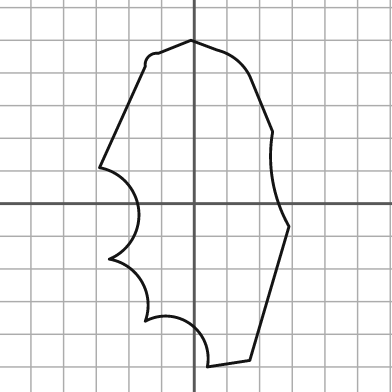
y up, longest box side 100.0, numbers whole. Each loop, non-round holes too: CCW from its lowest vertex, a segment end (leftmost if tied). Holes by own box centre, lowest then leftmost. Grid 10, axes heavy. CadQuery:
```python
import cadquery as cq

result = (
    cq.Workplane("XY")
    .moveTo(4.0, -50.0)
    .lineTo(17.0, -48.0)
    .lineTo(29.0, -7.0)
    .threePointArc((24.0, 7.0), (24.0, 22.0))
    .lineTo(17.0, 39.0)
    .threePointArc((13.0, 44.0), (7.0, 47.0))
    .lineTo(-1.0, 50.0)
    .lineTo(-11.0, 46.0)
    .threePointArc((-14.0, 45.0), (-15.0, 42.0))
    .lineTo(-29.0, 11.0)
    .threePointArc((-17.0, -2.0), (-26.0, -17.0))
    .threePointArc((-16.0, -24.0), (-15.0, -36.0))
    .threePointArc((-1.0, -37.0), (4.0, -50.0))
    .close()
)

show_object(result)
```